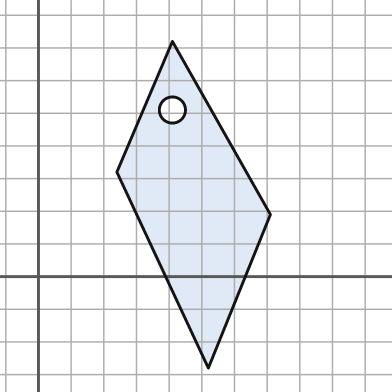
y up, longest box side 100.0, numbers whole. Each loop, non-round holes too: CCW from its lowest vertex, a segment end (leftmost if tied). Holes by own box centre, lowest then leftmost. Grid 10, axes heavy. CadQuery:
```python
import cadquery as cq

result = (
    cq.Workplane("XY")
    .moveTo(52.0, -28.0)
    .lineTo(71.0, 19.0)
    .lineTo(41.0, 72.0)
    .lineTo(24.0, 32.0)
    .close()
    .moveTo(41.0, 51.0)
    .circle(4.0)
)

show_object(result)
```